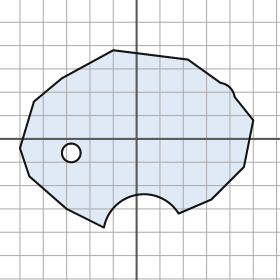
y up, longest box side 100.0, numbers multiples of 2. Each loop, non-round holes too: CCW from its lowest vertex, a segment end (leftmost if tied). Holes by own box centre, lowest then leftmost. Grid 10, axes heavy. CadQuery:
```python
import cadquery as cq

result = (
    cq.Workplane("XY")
    .moveTo(-14.0, -38.0)
    .threePointArc((0.0, -24.0), (18.0, -32.0))
    .lineTo(32.0, -26.0)
    .lineTo(46.0, -12.0)
    .lineTo(50.0, 8.0)
    .lineTo(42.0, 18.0)
    .threePointArc((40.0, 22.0), (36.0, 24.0))
    .lineTo(22.0, 34.0)
    .lineTo(-10.0, 38.0)
    .lineTo(-32.0, 26.0)
    .lineTo(-44.0, 16.0)
    .lineTo(-50.0, -4.0)
    .lineTo(-46.0, -16.0)
    .lineTo(-30.0, -30.0)
    .close()
    .moveTo(-28.0, -6.0)
    .circle(4.0)
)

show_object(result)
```